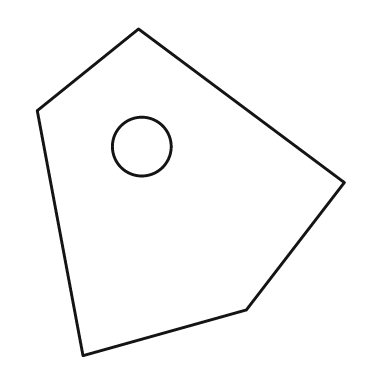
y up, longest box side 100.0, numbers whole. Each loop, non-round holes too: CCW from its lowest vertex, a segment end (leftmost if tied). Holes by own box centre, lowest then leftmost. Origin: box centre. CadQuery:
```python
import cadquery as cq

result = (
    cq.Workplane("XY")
    .moveTo(-33.0, -50.0)
    .lineTo(17.0, -36.0)
    .lineTo(47.0, 3.0)
    .lineTo(-16.0, 50.0)
    .lineTo(-47.0, 25.0)
    .close()
    .moveTo(-15.0, 14.0)
    .circle(9.0)
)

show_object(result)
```